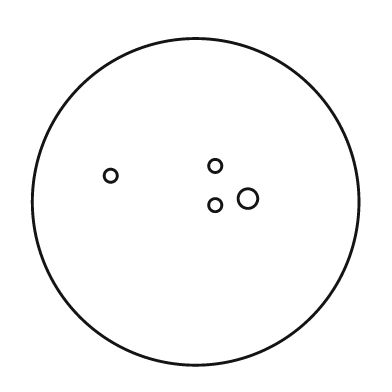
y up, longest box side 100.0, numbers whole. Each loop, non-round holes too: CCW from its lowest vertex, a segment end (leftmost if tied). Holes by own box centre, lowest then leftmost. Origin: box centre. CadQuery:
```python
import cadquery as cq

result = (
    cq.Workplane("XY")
    .moveTo(0.0, 0.0)
    .circle(50.0)
    .moveTo(6.0, -1.0)
    .circle(2.0)
    .moveTo(16.0, 1.0)
    .circle(3.0)
    .moveTo(-26.0, 8.0)
    .circle(2.0)
    .moveTo(6.0, 11.0)
    .circle(2.0)
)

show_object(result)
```